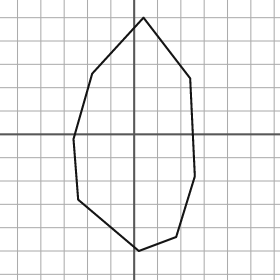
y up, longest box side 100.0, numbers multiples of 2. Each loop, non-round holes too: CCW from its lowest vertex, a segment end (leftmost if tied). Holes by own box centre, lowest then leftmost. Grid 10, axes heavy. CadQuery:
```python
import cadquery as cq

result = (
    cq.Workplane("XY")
    .moveTo(2.0, -50.0)
    .lineTo(18.0, -44.0)
    .lineTo(26.0, -18.0)
    .lineTo(24.0, 24.0)
    .lineTo(4.0, 50.0)
    .lineTo(-18.0, 26.0)
    .lineTo(-26.0, -2.0)
    .lineTo(-24.0, -28.0)
    .close()
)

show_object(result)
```